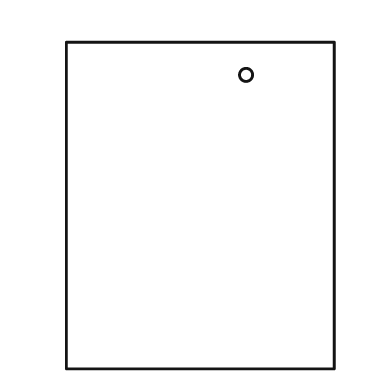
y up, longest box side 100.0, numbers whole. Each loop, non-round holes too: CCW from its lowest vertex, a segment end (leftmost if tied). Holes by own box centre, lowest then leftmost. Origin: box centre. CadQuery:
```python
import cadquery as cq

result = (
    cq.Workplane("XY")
    .moveTo(-41.0, -50.0)
    .lineTo(41.0, -50.0)
    .lineTo(41.0, 50.0)
    .lineTo(-41.0, 50.0)
    .close()
    .moveTo(14.0, 40.0)
    .circle(2.0)
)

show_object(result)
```